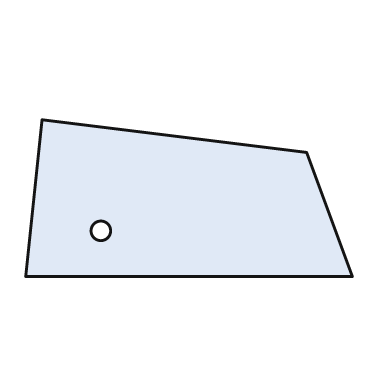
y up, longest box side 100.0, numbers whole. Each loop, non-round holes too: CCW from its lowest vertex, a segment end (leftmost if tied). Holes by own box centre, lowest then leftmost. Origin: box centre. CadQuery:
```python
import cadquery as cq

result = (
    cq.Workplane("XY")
    .moveTo(-50.0, -24.0)
    .lineTo(50.0, -24.0)
    .lineTo(36.0, 14.0)
    .lineTo(-45.0, 24.0)
    .close()
    .moveTo(-27.0, -10.0)
    .circle(3.0)
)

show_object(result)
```